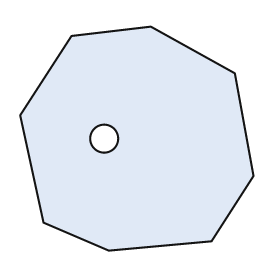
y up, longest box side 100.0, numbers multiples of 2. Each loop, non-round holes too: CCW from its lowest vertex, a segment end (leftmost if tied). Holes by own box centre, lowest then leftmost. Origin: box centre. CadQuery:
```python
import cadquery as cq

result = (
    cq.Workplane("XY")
    .moveTo(-12.0, -48.0)
    .lineTo(32.0, -44.0)
    .lineTo(50.0, -16.0)
    .lineTo(42.0, 28.0)
    .lineTo(6.0, 48.0)
    .lineTo(-28.0, 44.0)
    .lineTo(-50.0, 10.0)
    .lineTo(-40.0, -36.0)
    .close()
    .moveTo(-14.0, 0.0)
    .circle(6.0)
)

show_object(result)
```